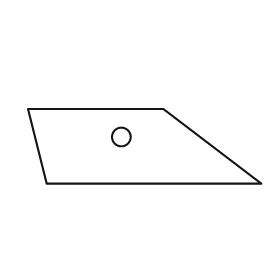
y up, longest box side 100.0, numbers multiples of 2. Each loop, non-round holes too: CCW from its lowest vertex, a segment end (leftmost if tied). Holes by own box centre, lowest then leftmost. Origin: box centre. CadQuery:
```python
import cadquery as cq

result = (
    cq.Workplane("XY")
    .moveTo(-42.0, -16.0)
    .lineTo(50.0, -16.0)
    .lineTo(8.0, 16.0)
    .lineTo(-50.0, 16.0)
    .close()
    .moveTo(-10.0, 4.0)
    .circle(4.0)
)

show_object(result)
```